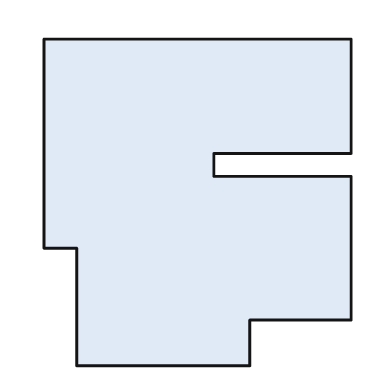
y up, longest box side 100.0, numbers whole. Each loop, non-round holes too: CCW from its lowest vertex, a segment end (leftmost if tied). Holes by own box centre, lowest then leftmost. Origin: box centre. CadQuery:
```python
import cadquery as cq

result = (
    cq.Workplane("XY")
    .moveTo(-37.0, -50.0)
    .lineTo(16.0, -50.0)
    .lineTo(16.0, -36.0)
    .lineTo(47.0, -36.0)
    .lineTo(47.0, 8.0)
    .lineTo(5.0, 8.0)
    .lineTo(5.0, 15.0)
    .lineTo(47.0, 15.0)
    .lineTo(47.0, 50.0)
    .lineTo(-47.0, 50.0)
    .lineTo(-47.0, -14.0)
    .lineTo(-37.0, -14.0)
    .close()
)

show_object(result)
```